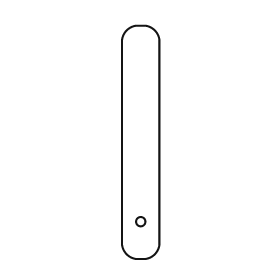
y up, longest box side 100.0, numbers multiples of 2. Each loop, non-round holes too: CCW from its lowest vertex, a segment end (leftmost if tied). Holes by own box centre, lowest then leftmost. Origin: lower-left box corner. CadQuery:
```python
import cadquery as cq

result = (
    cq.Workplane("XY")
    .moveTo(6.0, 0.0)
    .lineTo(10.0, 0.0)
    .threePointArc((14.0, 2.0), (16.0, 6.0))
    .lineTo(16.0, 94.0)
    .threePointArc((14.0, 98.0), (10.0, 100.0))
    .lineTo(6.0, 100.0)
    .threePointArc((2.0, 98.0), (0.0, 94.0))
    .lineTo(0.0, 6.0)
    .threePointArc((2.0, 2.0), (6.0, 0.0))
    .close()
    .moveTo(8.0, 16.0)
    .circle(2.0)
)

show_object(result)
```